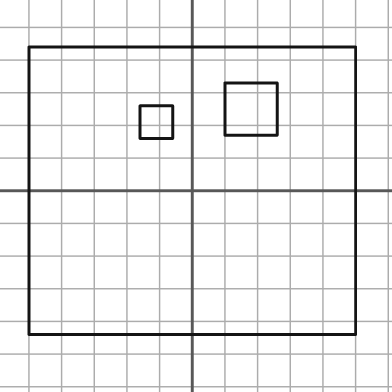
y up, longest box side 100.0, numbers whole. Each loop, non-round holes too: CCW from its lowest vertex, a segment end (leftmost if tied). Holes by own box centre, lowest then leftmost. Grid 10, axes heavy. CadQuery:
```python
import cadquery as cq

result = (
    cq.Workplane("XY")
    .moveTo(-50.0, -44.0)
    .lineTo(50.0, -44.0)
    .lineTo(50.0, 44.0)
    .lineTo(-50.0, 44.0)
    .close()
    .moveTo(-16.0, 16.0)
    .lineTo(-6.0, 16.0)
    .lineTo(-6.0, 26.0)
    .lineTo(-16.0, 26.0)
    .close()
    .moveTo(10.0, 17.0)
    .lineTo(26.0, 17.0)
    .lineTo(26.0, 33.0)
    .lineTo(10.0, 33.0)
    .close()
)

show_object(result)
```